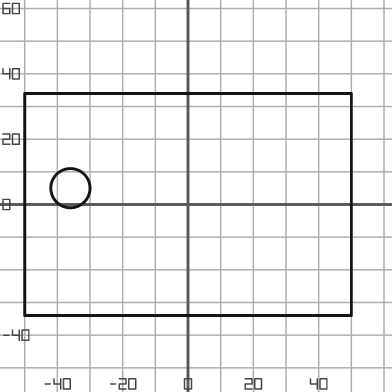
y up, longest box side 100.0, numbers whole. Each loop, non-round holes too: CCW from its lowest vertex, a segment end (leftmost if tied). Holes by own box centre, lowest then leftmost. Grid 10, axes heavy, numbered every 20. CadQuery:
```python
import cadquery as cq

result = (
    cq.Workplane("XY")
    .moveTo(-50.0, -34.0)
    .lineTo(50.0, -34.0)
    .lineTo(50.0, 34.0)
    .lineTo(-50.0, 34.0)
    .close()
    .moveTo(-36.0, 5.0)
    .circle(6.0)
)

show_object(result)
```